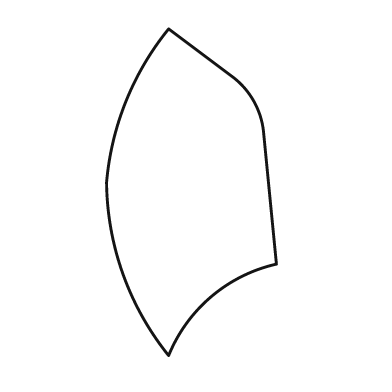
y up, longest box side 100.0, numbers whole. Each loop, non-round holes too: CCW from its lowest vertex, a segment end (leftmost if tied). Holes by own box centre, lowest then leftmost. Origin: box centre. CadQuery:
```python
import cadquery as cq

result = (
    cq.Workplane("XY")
    .moveTo(-7.0, -50.0)
    .threePointArc((6.0, -32.0), (26.0, -22.0))
    .lineTo(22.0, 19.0)
    .threePointArc((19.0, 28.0), (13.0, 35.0))
    .lineTo(-7.0, 50.0)
    .threePointArc((-20.0, 28.0), (-26.0, 3.0))
    .threePointArc((-21.0, -25.0), (-7.0, -50.0))
    .close()
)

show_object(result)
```